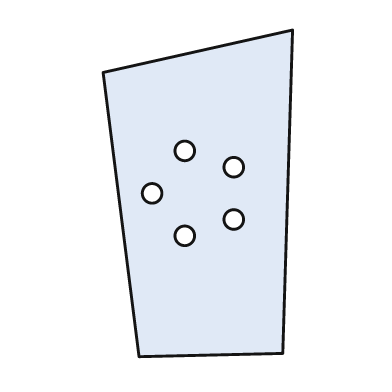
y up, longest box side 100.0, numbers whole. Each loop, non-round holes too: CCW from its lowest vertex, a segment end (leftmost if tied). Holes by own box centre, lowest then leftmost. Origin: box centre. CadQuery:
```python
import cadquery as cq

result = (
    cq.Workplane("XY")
    .moveTo(-18.0, -50.0)
    .lineTo(26.0, -49.0)
    .lineTo(29.0, 50.0)
    .lineTo(-29.0, 37.0)
    .close()
    .moveTo(-4.0, -13.0)
    .circle(3.0)
    .moveTo(11.0, -8.0)
    .circle(3.0)
    .moveTo(-14.0, 0.0)
    .circle(3.0)
    .moveTo(11.0, 8.0)
    .circle(3.0)
    .moveTo(-4.0, 13.0)
    .circle(3.0)
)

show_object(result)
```